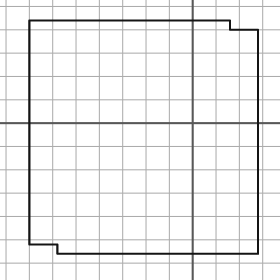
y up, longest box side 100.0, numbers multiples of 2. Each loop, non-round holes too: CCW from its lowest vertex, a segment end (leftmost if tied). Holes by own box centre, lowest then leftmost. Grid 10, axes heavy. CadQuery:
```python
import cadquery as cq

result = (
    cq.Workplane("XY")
    .moveTo(-58.0, -56.0)
    .lineTo(28.0, -56.0)
    .lineTo(28.0, 40.0)
    .lineTo(16.0, 40.0)
    .lineTo(16.0, 44.0)
    .lineTo(-70.0, 44.0)
    .lineTo(-70.0, -52.0)
    .lineTo(-58.0, -52.0)
    .close()
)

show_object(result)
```